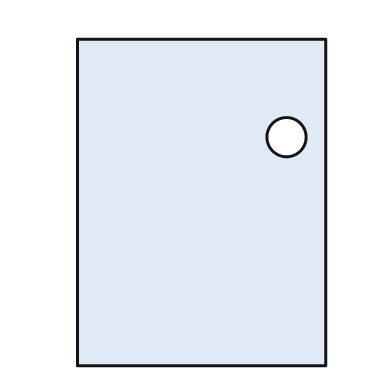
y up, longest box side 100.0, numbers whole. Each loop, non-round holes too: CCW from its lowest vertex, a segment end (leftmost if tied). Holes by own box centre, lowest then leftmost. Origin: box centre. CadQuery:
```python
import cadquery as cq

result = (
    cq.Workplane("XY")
    .moveTo(-38.0, -50.0)
    .lineTo(38.0, -50.0)
    .lineTo(38.0, 50.0)
    .lineTo(-38.0, 50.0)
    .close()
    .moveTo(26.0, 20.0)
    .circle(6.0)
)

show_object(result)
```